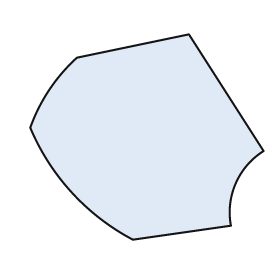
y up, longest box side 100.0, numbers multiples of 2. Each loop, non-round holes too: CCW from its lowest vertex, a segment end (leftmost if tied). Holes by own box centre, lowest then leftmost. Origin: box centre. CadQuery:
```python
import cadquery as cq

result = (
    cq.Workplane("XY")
    .moveTo(-6.0, -44.0)
    .lineTo(36.0, -38.0)
    .threePointArc((38.0, -20.0), (50.0, -6.0))
    .lineTo(18.0, 44.0)
    .lineTo(-30.0, 34.0)
    .threePointArc((-42.0, 20.0), (-50.0, 4.0))
    .threePointArc((-32.0, -24.0), (-6.0, -44.0))
    .close()
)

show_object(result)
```